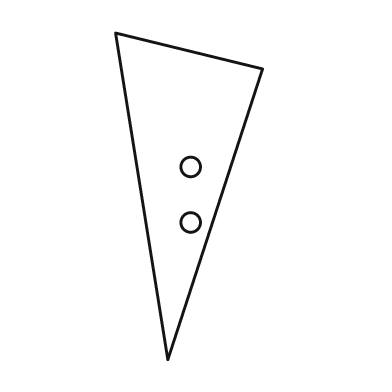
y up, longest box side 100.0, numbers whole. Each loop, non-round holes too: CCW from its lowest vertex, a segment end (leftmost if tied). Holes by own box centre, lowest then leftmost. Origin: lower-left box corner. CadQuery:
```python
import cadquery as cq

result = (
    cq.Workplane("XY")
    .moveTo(16.0, 0.0)
    .lineTo(45.0, 89.0)
    .lineTo(0.0, 100.0)
    .close()
    .moveTo(23.0, 42.0)
    .circle(3.0)
    .moveTo(23.0, 59.0)
    .circle(3.0)
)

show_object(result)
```